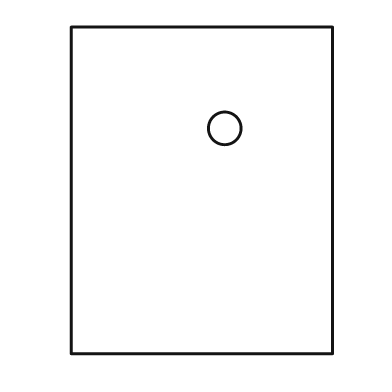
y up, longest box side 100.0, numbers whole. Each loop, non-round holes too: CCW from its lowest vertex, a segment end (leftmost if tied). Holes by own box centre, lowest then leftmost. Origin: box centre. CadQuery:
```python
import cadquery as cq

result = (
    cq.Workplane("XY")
    .moveTo(-40.0, -50.0)
    .lineTo(40.0, -50.0)
    .lineTo(40.0, 50.0)
    .lineTo(-40.0, 50.0)
    .close()
    .moveTo(7.0, 19.0)
    .circle(5.0)
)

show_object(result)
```